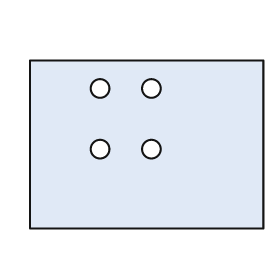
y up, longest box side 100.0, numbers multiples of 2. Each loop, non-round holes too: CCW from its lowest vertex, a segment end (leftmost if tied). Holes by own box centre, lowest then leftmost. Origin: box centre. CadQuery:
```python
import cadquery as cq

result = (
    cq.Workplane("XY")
    .moveTo(-50.0, -36.0)
    .lineTo(50.0, -36.0)
    .lineTo(50.0, 36.0)
    .lineTo(-50.0, 36.0)
    .close()
    .moveTo(-20.0, -2.0)
    .circle(4.0)
    .moveTo(2.0, -2.0)
    .circle(4.0)
    .moveTo(-20.0, 24.0)
    .circle(4.0)
    .moveTo(2.0, 24.0)
    .circle(4.0)
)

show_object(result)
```